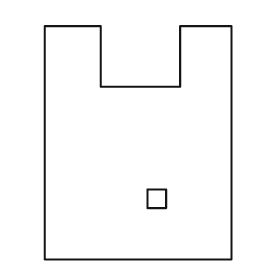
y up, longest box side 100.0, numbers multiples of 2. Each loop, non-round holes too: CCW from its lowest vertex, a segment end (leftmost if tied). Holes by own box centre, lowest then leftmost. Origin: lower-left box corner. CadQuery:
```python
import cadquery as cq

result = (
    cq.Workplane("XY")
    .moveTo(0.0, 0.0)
    .lineTo(80.0, 0.0)
    .lineTo(80.0, 100.0)
    .lineTo(58.0, 100.0)
    .lineTo(58.0, 74.0)
    .lineTo(24.0, 74.0)
    .lineTo(24.0, 100.0)
    .lineTo(0.0, 100.0)
    .close()
    .moveTo(44.0, 22.0)
    .lineTo(52.0, 22.0)
    .lineTo(52.0, 30.0)
    .lineTo(44.0, 30.0)
    .close()
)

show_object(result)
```